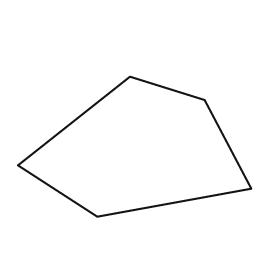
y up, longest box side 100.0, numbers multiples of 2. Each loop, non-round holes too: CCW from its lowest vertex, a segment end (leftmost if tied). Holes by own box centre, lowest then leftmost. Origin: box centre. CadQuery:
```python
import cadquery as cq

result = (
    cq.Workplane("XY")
    .moveTo(-16.0, -30.0)
    .lineTo(50.0, -18.0)
    .lineTo(30.0, 20.0)
    .lineTo(-2.0, 30.0)
    .lineTo(-50.0, -8.0)
    .close()
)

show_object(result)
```